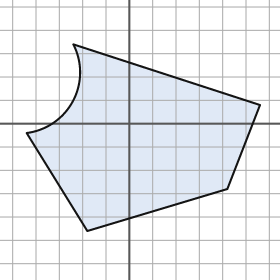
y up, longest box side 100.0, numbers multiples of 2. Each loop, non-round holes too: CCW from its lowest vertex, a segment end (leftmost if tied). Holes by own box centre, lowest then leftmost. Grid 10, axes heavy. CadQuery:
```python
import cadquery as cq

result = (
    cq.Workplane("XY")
    .moveTo(-18.0, -46.0)
    .lineTo(42.0, -28.0)
    .lineTo(56.0, 8.0)
    .lineTo(-24.0, 34.0)
    .threePointArc((-24.0, 10.0), (-44.0, -4.0))
    .close()
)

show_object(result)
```